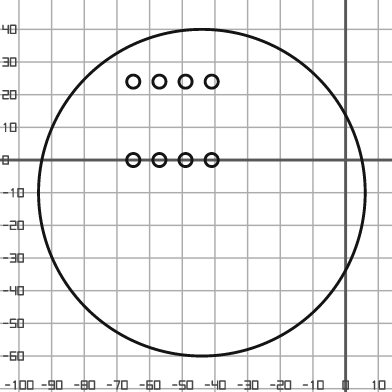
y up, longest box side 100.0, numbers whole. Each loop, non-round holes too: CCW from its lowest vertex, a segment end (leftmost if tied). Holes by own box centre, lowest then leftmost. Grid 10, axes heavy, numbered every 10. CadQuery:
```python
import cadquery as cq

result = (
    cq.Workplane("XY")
    .moveTo(-44.0, -10.0)
    .circle(50.0)
    .moveTo(-65.0, 0.0)
    .circle(2.0)
    .moveTo(-57.0, 0.0)
    .circle(2.0)
    .moveTo(-49.0, 0.0)
    .circle(2.0)
    .moveTo(-41.0, 0.0)
    .circle(2.0)
    .moveTo(-65.0, 24.0)
    .circle(2.0)
    .moveTo(-57.0, 24.0)
    .circle(2.0)
    .moveTo(-49.0, 24.0)
    .circle(2.0)
    .moveTo(-41.0, 24.0)
    .circle(2.0)
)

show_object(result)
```